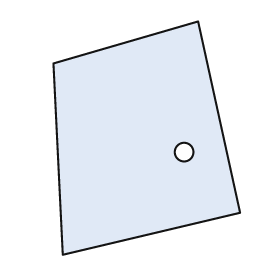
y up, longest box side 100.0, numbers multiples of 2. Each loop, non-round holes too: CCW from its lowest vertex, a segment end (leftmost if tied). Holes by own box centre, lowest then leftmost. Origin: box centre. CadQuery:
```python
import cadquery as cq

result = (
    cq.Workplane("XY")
    .moveTo(-36.0, -50.0)
    .lineTo(40.0, -32.0)
    .lineTo(22.0, 50.0)
    .lineTo(-40.0, 32.0)
    .close()
    .moveTo(16.0, -6.0)
    .circle(4.0)
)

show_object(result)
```